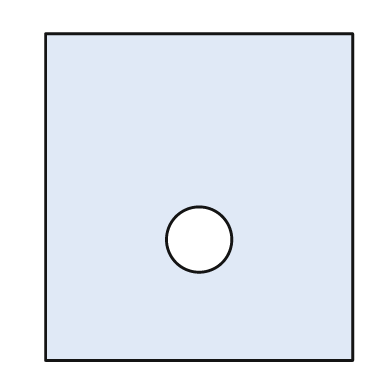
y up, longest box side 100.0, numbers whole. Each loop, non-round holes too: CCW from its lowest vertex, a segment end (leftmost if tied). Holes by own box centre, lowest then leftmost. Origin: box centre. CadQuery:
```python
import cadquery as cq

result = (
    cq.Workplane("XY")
    .moveTo(-47.0, -50.0)
    .lineTo(47.0, -50.0)
    .lineTo(47.0, 50.0)
    .lineTo(-47.0, 50.0)
    .close()
    .moveTo(0.0, -13.0)
    .circle(10.0)
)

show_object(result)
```